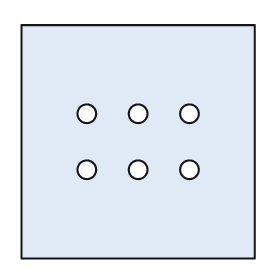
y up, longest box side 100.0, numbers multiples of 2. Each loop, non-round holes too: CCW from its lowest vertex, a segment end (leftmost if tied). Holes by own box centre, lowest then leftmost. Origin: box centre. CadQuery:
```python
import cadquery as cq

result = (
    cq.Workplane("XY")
    .moveTo(-50.0, -50.0)
    .lineTo(50.0, -50.0)
    .lineTo(50.0, 50.0)
    .lineTo(-50.0, 50.0)
    .close()
    .moveTo(-22.0, -12.0)
    .circle(4.0)
    .moveTo(0.0, -12.0)
    .circle(4.0)
    .moveTo(22.0, -12.0)
    .circle(4.0)
    .moveTo(-22.0, 12.0)
    .circle(4.0)
    .moveTo(0.0, 12.0)
    .circle(4.0)
    .moveTo(22.0, 12.0)
    .circle(4.0)
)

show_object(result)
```